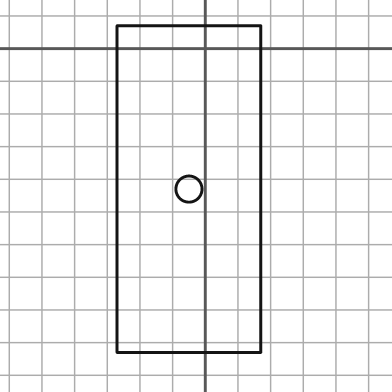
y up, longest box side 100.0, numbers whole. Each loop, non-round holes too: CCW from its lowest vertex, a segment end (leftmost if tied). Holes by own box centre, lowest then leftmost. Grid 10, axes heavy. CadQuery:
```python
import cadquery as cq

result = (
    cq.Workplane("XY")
    .moveTo(-27.0, -93.0)
    .lineTo(17.0, -93.0)
    .lineTo(17.0, 7.0)
    .lineTo(-27.0, 7.0)
    .close()
    .moveTo(-5.0, -43.0)
    .circle(4.0)
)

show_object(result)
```